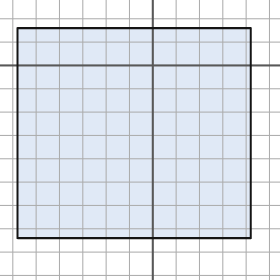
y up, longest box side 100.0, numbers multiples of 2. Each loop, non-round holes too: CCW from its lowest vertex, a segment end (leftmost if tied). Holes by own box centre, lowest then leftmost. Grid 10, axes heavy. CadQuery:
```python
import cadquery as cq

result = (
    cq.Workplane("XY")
    .moveTo(-58.0, -74.0)
    .lineTo(42.0, -74.0)
    .lineTo(42.0, 16.0)
    .lineTo(-58.0, 16.0)
    .close()
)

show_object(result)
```